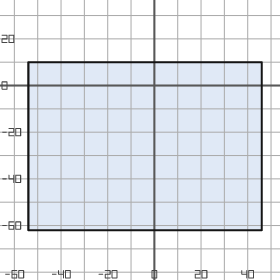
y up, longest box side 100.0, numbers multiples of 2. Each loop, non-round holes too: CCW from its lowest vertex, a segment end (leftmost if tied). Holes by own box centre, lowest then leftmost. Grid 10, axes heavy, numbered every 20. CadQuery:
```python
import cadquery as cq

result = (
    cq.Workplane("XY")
    .moveTo(-54.0, -62.0)
    .lineTo(46.0, -62.0)
    .lineTo(46.0, 10.0)
    .lineTo(-54.0, 10.0)
    .close()
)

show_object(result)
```